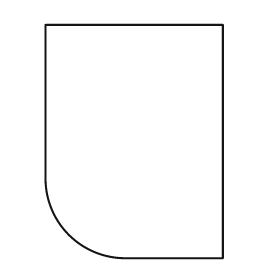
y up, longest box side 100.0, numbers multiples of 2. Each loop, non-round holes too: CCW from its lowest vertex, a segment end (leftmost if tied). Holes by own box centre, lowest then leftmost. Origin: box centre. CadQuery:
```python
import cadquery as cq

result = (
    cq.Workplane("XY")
    .moveTo(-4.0, -50.0)
    .lineTo(38.0, -50.0)
    .lineTo(38.0, 50.0)
    .lineTo(-38.0, 50.0)
    .lineTo(-38.0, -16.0)
    .threePointArc((-28.0, -40.0), (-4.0, -50.0))
    .close()
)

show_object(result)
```